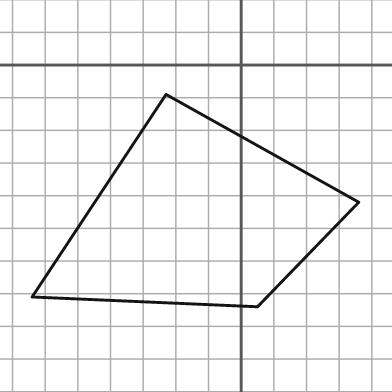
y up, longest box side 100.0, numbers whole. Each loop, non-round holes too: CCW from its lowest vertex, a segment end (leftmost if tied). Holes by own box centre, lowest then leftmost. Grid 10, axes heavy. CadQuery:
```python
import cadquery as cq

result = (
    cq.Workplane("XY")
    .moveTo(5.0, -74.0)
    .lineTo(36.0, -42.0)
    .lineTo(-23.0, -9.0)
    .lineTo(-64.0, -71.0)
    .close()
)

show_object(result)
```